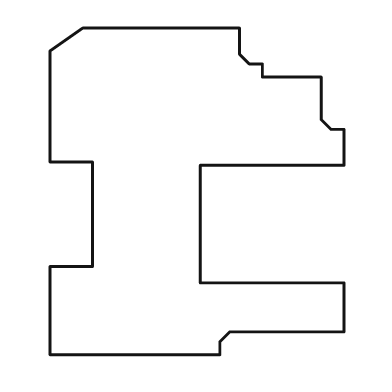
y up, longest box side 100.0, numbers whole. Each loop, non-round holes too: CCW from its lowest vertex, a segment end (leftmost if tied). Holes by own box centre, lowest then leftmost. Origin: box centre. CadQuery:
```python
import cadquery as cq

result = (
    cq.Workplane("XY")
    .moveTo(-45.0, -50.0)
    .lineTo(7.0, -50.0)
    .lineTo(7.0, -46.0)
    .lineTo(10.0, -43.0)
    .lineTo(45.0, -43.0)
    .lineTo(45.0, -28.0)
    .lineTo(1.0, -28.0)
    .lineTo(1.0, 8.0)
    .lineTo(45.0, 8.0)
    .lineTo(45.0, 19.0)
    .lineTo(41.0, 19.0)
    .lineTo(38.0, 22.0)
    .lineTo(38.0, 35.0)
    .lineTo(20.0, 35.0)
    .lineTo(20.0, 39.0)
    .lineTo(16.0, 39.0)
    .lineTo(13.0, 42.0)
    .lineTo(13.0, 50.0)
    .lineTo(-35.0, 50.0)
    .lineTo(-45.0, 43.0)
    .lineTo(-45.0, 9.0)
    .lineTo(-32.0, 9.0)
    .lineTo(-32.0, -23.0)
    .lineTo(-45.0, -23.0)
    .close()
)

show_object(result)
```